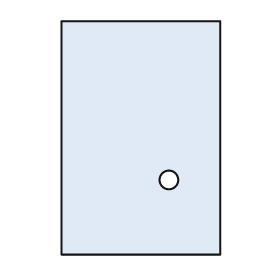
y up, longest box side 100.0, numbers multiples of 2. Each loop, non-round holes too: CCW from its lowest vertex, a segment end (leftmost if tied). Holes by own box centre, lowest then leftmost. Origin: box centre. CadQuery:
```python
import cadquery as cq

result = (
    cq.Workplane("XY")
    .moveTo(-34.0, -50.0)
    .lineTo(34.0, -50.0)
    .lineTo(34.0, 50.0)
    .lineTo(-34.0, 50.0)
    .close()
    .moveTo(12.0, -18.0)
    .circle(4.0)
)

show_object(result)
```